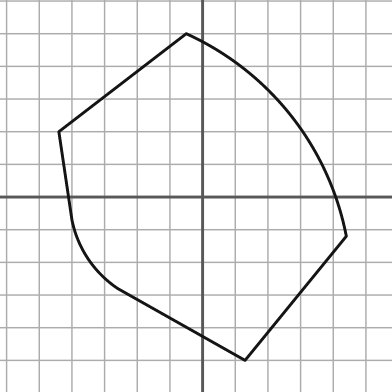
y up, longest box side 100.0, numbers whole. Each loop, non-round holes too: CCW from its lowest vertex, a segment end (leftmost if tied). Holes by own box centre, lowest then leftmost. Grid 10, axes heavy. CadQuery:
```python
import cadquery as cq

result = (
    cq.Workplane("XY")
    .moveTo(13.0, -50.0)
    .lineTo(44.0, -12.0)
    .threePointArc((27.0, 25.0), (-5.0, 50.0))
    .lineTo(-44.0, 20.0)
    .lineTo(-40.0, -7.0)
    .threePointArc((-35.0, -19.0), (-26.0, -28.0))
    .close()
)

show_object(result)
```